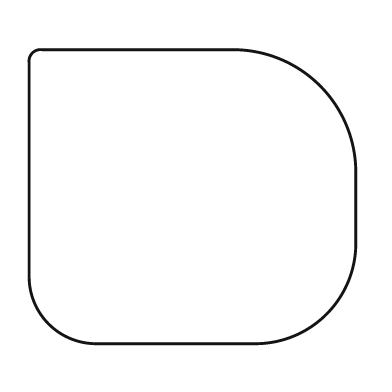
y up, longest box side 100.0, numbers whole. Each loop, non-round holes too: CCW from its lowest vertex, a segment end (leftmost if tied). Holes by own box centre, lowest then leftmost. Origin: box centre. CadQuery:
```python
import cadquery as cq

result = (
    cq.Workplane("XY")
    .moveTo(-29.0, -45.0)
    .lineTo(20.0, -45.0)
    .threePointArc((41.0, -36.0), (50.0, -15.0))
    .lineTo(50.0, 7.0)
    .threePointArc((39.0, 34.0), (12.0, 45.0))
    .lineTo(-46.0, 45.0)
    .threePointArc((-49.0, 44.0), (-50.0, 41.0))
    .lineTo(-50.0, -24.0)
    .threePointArc((-44.0, -39.0), (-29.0, -45.0))
    .close()
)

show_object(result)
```